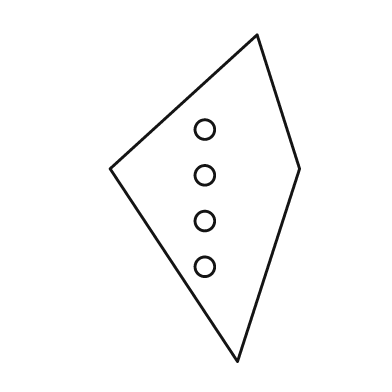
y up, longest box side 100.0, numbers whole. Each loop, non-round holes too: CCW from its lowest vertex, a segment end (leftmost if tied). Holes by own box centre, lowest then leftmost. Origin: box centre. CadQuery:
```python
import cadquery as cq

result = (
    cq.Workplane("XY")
    .moveTo(10.0, -50.0)
    .lineTo(29.0, 9.0)
    .lineTo(16.0, 50.0)
    .lineTo(-29.0, 9.0)
    .close()
    .moveTo(0.0, -21.0)
    .circle(3.0)
    .moveTo(0.0, -7.0)
    .circle(3.0)
    .moveTo(0.0, 7.0)
    .circle(3.0)
    .moveTo(0.0, 21.0)
    .circle(3.0)
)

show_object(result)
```